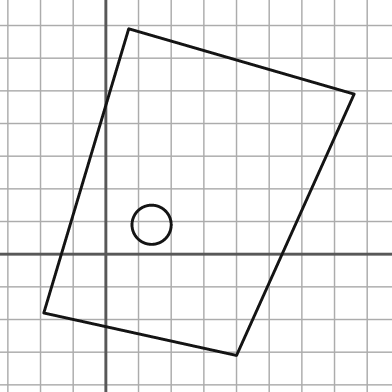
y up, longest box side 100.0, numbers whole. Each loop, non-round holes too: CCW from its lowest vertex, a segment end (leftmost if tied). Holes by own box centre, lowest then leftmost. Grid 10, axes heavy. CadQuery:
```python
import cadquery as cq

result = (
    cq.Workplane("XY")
    .moveTo(40.0, -31.0)
    .lineTo(76.0, 49.0)
    .lineTo(7.0, 69.0)
    .lineTo(-19.0, -18.0)
    .close()
    .moveTo(14.0, 9.0)
    .circle(6.0)
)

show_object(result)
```